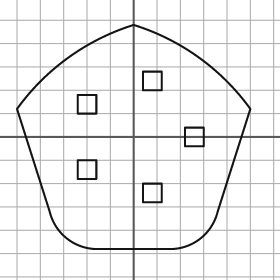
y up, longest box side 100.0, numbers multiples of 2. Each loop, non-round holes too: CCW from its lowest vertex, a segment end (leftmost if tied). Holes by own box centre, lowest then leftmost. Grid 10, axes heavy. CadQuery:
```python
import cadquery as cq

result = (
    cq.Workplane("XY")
    .moveTo(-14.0, -48.0)
    .lineTo(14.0, -48.0)
    .threePointArc((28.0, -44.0), (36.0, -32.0))
    .lineTo(50.0, 12.0)
    .threePointArc((28.0, 34.0), (0.0, 48.0))
    .threePointArc((-28.0, 34.0), (-50.0, 12.0))
    .lineTo(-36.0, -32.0)
    .threePointArc((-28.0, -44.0), (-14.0, -48.0))
    .close()
    .moveTo(4.0, -28.0)
    .lineTo(12.0, -28.0)
    .lineTo(12.0, -20.0)
    .lineTo(4.0, -20.0)
    .close()
    .moveTo(-24.0, -18.0)
    .lineTo(-16.0, -18.0)
    .lineTo(-16.0, -10.0)
    .lineTo(-24.0, -10.0)
    .close()
    .moveTo(22.0, -4.0)
    .lineTo(30.0, -4.0)
    .lineTo(30.0, 4.0)
    .lineTo(22.0, 4.0)
    .close()
    .moveTo(-24.0, 10.0)
    .lineTo(-16.0, 10.0)
    .lineTo(-16.0, 18.0)
    .lineTo(-24.0, 18.0)
    .close()
    .moveTo(4.0, 20.0)
    .lineTo(12.0, 20.0)
    .lineTo(12.0, 28.0)
    .lineTo(4.0, 28.0)
    .close()
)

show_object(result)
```